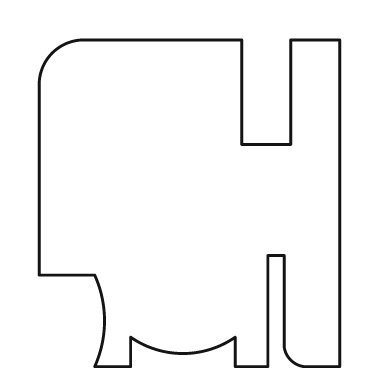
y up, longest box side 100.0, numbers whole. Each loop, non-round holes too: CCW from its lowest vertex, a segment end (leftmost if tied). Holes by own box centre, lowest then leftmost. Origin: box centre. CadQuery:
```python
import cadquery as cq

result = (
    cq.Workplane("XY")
    .moveTo(-29.0, -50.0)
    .lineTo(-18.0, -50.0)
    .lineTo(-18.0, -41.0)
    .threePointArc((-2.0, -46.0), (14.0, -41.0))
    .lineTo(14.0, -50.0)
    .lineTo(24.0, -50.0)
    .lineTo(24.0, -16.0)
    .lineTo(29.0, -16.0)
    .lineTo(29.0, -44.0)
    .threePointArc((31.0, -48.0), (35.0, -50.0))
    .lineTo(46.0, -50.0)
    .lineTo(46.0, 50.0)
    .lineTo(31.0, 50.0)
    .lineTo(31.0, 18.0)
    .lineTo(16.0, 18.0)
    .lineTo(16.0, 50.0)
    .lineTo(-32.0, 50.0)
    .threePointArc((-42.0, 46.0), (-46.0, 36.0))
    .lineTo(-46.0, -22.0)
    .lineTo(-29.0, -22.0)
    .threePointArc((-26.0, -36.0), (-29.0, -50.0))
    .close()
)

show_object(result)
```